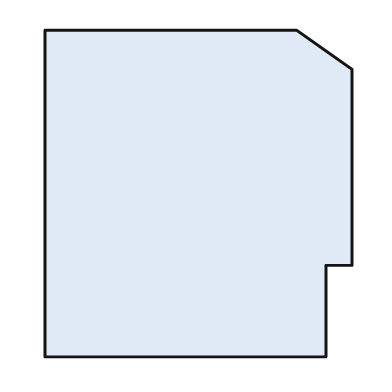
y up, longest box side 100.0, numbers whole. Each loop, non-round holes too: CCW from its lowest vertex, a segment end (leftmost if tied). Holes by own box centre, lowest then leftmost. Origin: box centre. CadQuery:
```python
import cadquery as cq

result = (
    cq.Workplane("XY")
    .moveTo(-47.0, -50.0)
    .lineTo(39.0, -50.0)
    .lineTo(39.0, -22.0)
    .lineTo(47.0, -22.0)
    .lineTo(47.0, 38.0)
    .lineTo(30.0, 50.0)
    .lineTo(-47.0, 50.0)
    .close()
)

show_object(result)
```